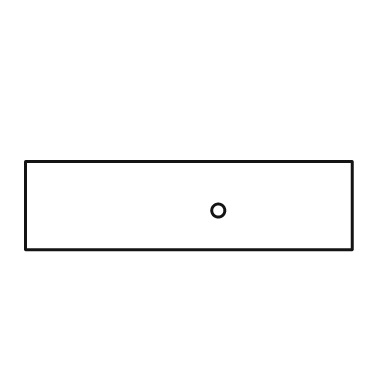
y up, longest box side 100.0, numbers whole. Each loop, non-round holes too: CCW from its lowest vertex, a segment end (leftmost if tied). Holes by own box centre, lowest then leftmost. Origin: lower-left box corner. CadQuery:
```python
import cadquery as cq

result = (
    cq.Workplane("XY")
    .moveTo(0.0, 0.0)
    .lineTo(100.0, 0.0)
    .lineTo(100.0, 27.0)
    .lineTo(0.0, 27.0)
    .close()
    .moveTo(59.0, 12.0)
    .circle(2.0)
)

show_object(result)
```